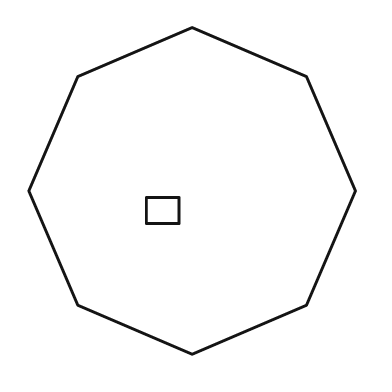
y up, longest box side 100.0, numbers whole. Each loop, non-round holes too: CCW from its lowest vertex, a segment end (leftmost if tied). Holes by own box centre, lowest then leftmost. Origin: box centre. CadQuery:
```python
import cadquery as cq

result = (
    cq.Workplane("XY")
    .moveTo(0.0, -50.0)
    .lineTo(35.0, -35.0)
    .lineTo(50.0, 0.0)
    .lineTo(35.0, 35.0)
    .lineTo(0.0, 50.0)
    .lineTo(-35.0, 35.0)
    .lineTo(-50.0, 0.0)
    .lineTo(-35.0, -35.0)
    .close()
    .moveTo(-14.0, -10.0)
    .lineTo(-4.0, -10.0)
    .lineTo(-4.0, -2.0)
    .lineTo(-14.0, -2.0)
    .close()
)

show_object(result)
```